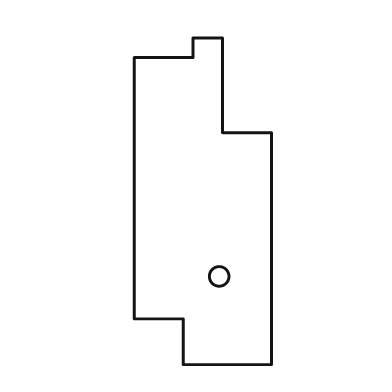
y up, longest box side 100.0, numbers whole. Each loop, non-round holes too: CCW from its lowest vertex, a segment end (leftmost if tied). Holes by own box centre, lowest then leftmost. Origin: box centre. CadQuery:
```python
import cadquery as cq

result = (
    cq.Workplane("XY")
    .moveTo(-6.0, -50.0)
    .lineTo(21.0, -50.0)
    .lineTo(21.0, 21.0)
    .lineTo(6.0, 21.0)
    .lineTo(6.0, 50.0)
    .lineTo(-3.0, 50.0)
    .lineTo(-3.0, 44.0)
    .lineTo(-21.0, 44.0)
    .lineTo(-21.0, -36.0)
    .lineTo(-6.0, -36.0)
    .close()
    .moveTo(5.0, -23.0)
    .circle(3.0)
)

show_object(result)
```